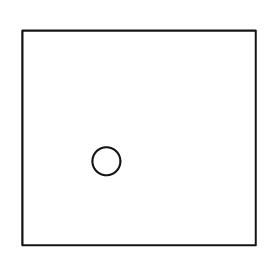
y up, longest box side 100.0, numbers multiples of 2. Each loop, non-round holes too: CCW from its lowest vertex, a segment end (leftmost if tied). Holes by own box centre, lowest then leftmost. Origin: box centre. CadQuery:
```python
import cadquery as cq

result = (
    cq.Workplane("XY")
    .moveTo(-50.0, -46.0)
    .lineTo(50.0, -46.0)
    .lineTo(50.0, 46.0)
    .lineTo(-50.0, 46.0)
    .close()
    .moveTo(-14.0, -10.0)
    .circle(6.0)
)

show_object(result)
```